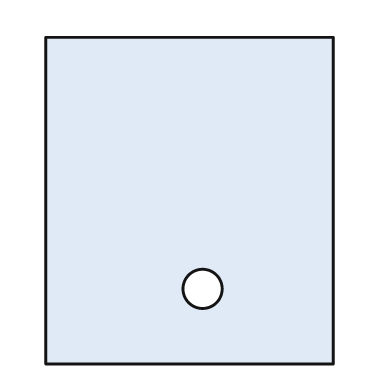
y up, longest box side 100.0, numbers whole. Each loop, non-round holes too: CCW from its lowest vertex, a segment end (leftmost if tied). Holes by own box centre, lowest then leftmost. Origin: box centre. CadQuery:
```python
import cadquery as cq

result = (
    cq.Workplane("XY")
    .moveTo(-44.0, -50.0)
    .lineTo(44.0, -50.0)
    .lineTo(44.0, 50.0)
    .lineTo(-44.0, 50.0)
    .close()
    .moveTo(4.0, -27.0)
    .circle(6.0)
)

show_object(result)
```